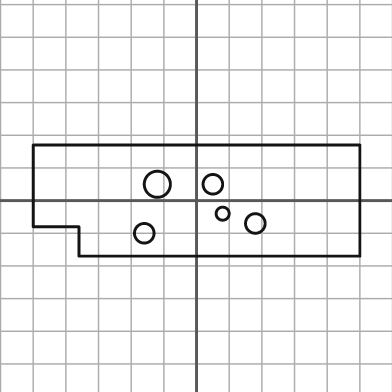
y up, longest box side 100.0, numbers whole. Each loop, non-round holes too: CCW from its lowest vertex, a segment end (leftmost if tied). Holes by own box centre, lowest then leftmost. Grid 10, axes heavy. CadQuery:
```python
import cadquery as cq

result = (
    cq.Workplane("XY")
    .moveTo(-36.0, -17.0)
    .lineTo(50.0, -17.0)
    .lineTo(50.0, 17.0)
    .lineTo(-50.0, 17.0)
    .lineTo(-50.0, -8.0)
    .lineTo(-36.0, -8.0)
    .close()
    .moveTo(-16.0, -10.0)
    .circle(3.0)
    .moveTo(18.0, -7.0)
    .circle(3.0)
    .moveTo(8.0, -4.0)
    .circle(2.0)
    .moveTo(-12.0, 5.0)
    .circle(4.0)
    .moveTo(5.0, 5.0)
    .circle(3.0)
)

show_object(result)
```